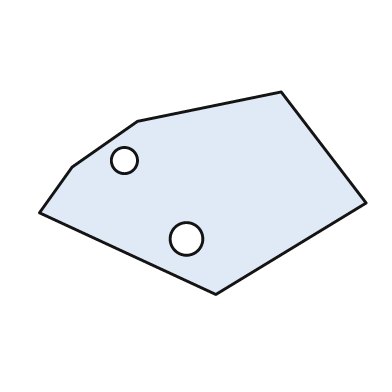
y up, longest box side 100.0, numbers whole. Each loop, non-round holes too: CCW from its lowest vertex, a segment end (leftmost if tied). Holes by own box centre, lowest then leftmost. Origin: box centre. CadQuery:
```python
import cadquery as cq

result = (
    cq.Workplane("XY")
    .moveTo(4.0, -31.0)
    .lineTo(50.0, -3.0)
    .lineTo(24.0, 31.0)
    .lineTo(-20.0, 22.0)
    .lineTo(-40.0, 8.0)
    .lineTo(-50.0, -6.0)
    .close()
    .moveTo(-5.0, -14.0)
    .circle(5.0)
    .moveTo(-24.0, 10.0)
    .circle(4.0)
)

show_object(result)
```